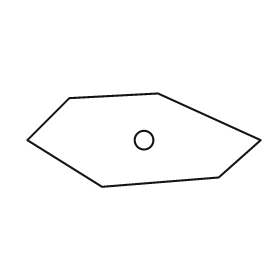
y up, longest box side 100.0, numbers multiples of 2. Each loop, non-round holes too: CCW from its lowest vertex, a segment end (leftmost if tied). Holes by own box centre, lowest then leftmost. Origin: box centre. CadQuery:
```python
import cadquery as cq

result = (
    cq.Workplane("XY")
    .moveTo(-18.0, -20.0)
    .lineTo(32.0, -16.0)
    .lineTo(50.0, 0.0)
    .lineTo(6.0, 20.0)
    .lineTo(-32.0, 18.0)
    .lineTo(-50.0, 0.0)
    .close()
    .moveTo(0.0, 0.0)
    .circle(4.0)
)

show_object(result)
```